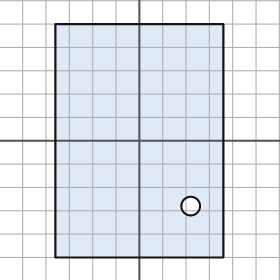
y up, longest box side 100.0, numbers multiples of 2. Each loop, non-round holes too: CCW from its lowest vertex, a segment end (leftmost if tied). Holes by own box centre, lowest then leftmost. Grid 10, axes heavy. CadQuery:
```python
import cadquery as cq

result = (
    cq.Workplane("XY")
    .moveTo(-36.0, -50.0)
    .lineTo(36.0, -50.0)
    .lineTo(36.0, 50.0)
    .lineTo(-36.0, 50.0)
    .close()
    .moveTo(22.0, -28.0)
    .circle(4.0)
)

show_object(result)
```